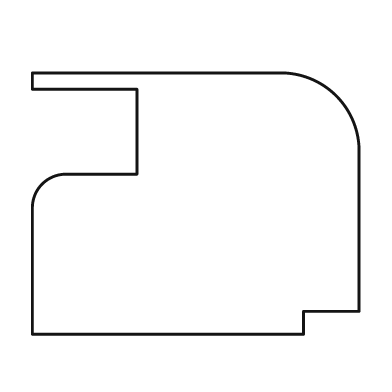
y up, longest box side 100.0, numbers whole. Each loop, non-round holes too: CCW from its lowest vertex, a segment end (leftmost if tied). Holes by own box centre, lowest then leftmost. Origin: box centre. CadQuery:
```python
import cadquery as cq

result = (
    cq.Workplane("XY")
    .moveTo(-50.0, -40.0)
    .lineTo(33.0, -40.0)
    .lineTo(33.0, -33.0)
    .lineTo(50.0, -33.0)
    .lineTo(50.0, 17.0)
    .threePointArc((43.0, 33.0), (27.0, 40.0))
    .lineTo(-50.0, 40.0)
    .lineTo(-50.0, 35.0)
    .lineTo(-18.0, 35.0)
    .lineTo(-18.0, 9.0)
    .lineTo(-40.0, 9.0)
    .threePointArc((-47.0, 6.0), (-50.0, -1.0))
    .close()
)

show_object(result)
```